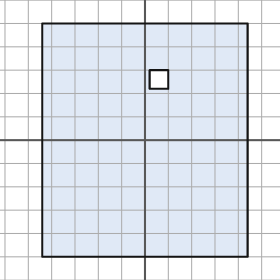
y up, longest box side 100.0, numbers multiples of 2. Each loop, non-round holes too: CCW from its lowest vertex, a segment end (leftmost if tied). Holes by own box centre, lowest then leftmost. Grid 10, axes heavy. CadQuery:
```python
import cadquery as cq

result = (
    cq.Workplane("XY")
    .moveTo(-44.0, -50.0)
    .lineTo(44.0, -50.0)
    .lineTo(44.0, 50.0)
    .lineTo(-44.0, 50.0)
    .close()
    .moveTo(2.0, 22.0)
    .lineTo(10.0, 22.0)
    .lineTo(10.0, 30.0)
    .lineTo(2.0, 30.0)
    .close()
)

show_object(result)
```